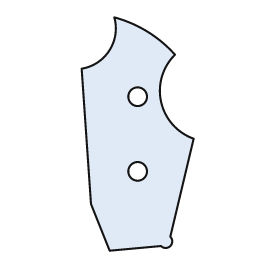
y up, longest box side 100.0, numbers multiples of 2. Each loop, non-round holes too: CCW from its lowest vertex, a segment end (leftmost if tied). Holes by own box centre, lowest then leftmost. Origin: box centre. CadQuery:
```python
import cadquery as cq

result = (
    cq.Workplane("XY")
    .moveTo(-12.0, -50.0)
    .lineTo(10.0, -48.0)
    .threePointArc((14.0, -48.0), (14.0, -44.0))
    .lineTo(24.0, -2.0)
    .threePointArc((10.0, 14.0), (16.0, 34.0))
    .threePointArc((4.0, 44.0), (-10.0, 50.0))
    .threePointArc((-12.0, 36.0), (-24.0, 28.0))
    .lineTo(-20.0, -30.0)
    .close()
    .moveTo(0.0, -16.0)
    .circle(4.0)
    .moveTo(0.0, 16.0)
    .circle(4.0)
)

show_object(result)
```